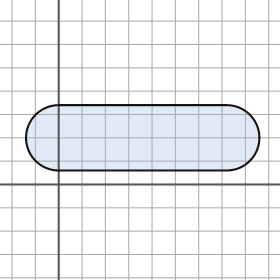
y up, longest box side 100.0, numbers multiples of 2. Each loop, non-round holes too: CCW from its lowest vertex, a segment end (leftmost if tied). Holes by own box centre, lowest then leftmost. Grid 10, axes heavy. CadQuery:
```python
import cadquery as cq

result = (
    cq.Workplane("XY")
    .moveTo(0.0, 6.0)
    .lineTo(72.0, 6.0)
    .threePointArc((86.0, 20.0), (72.0, 34.0))
    .lineTo(0.0, 34.0)
    .threePointArc((-14.0, 20.0), (0.0, 6.0))
    .close()
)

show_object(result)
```